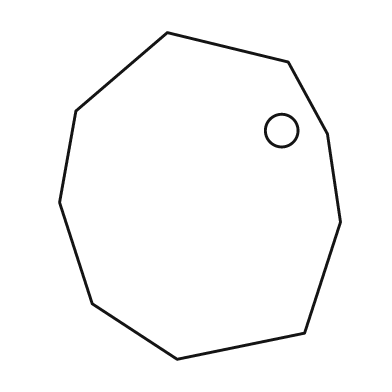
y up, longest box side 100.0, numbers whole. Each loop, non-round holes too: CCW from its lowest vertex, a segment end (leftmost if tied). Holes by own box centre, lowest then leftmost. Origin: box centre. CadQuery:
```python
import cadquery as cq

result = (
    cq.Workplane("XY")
    .moveTo(-7.0, -50.0)
    .lineTo(32.0, -42.0)
    .lineTo(43.0, -8.0)
    .lineTo(39.0, 19.0)
    .lineTo(27.0, 41.0)
    .lineTo(-10.0, 50.0)
    .lineTo(-38.0, 26.0)
    .lineTo(-43.0, -2.0)
    .lineTo(-33.0, -33.0)
    .close()
    .moveTo(25.0, 20.0)
    .circle(5.0)
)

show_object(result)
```